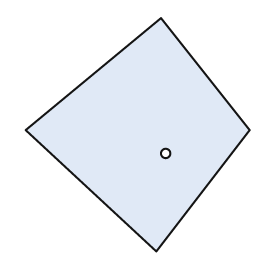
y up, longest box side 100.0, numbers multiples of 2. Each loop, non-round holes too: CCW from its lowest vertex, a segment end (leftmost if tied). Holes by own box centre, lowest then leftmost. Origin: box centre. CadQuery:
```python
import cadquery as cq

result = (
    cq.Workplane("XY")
    .moveTo(8.0, -50.0)
    .lineTo(48.0, 2.0)
    .lineTo(10.0, 50.0)
    .lineTo(-48.0, 2.0)
    .close()
    .moveTo(12.0, -8.0)
    .circle(2.0)
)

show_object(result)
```